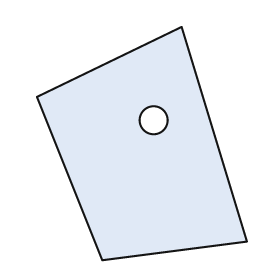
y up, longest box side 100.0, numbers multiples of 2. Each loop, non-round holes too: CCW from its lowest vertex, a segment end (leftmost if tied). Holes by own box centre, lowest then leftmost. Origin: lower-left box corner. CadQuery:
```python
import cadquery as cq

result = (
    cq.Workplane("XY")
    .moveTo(28.0, 0.0)
    .lineTo(90.0, 8.0)
    .lineTo(62.0, 100.0)
    .lineTo(0.0, 70.0)
    .close()
    .moveTo(50.0, 60.0)
    .circle(6.0)
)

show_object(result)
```